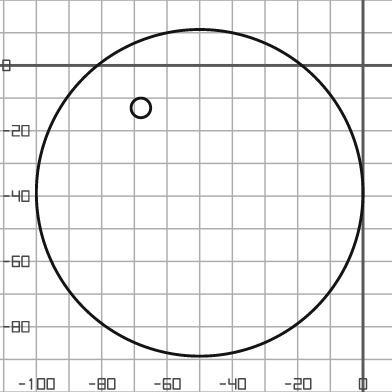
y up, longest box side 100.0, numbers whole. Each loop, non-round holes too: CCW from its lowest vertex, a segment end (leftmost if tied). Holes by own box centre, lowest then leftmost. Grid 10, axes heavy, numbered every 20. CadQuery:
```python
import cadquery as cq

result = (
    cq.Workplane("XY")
    .moveTo(-50.0, -39.0)
    .circle(50.0)
    .moveTo(-68.0, -13.0)
    .circle(3.0)
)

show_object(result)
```